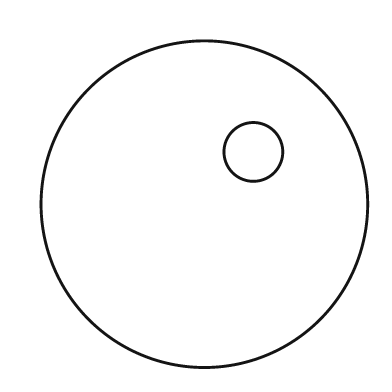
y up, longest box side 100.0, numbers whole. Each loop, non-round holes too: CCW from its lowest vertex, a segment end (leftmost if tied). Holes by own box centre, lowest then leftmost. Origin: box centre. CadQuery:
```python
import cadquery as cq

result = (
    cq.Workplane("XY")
    .moveTo(0.0, 0.0)
    .circle(50.0)
    .moveTo(15.0, 16.0)
    .circle(9.0)
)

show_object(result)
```